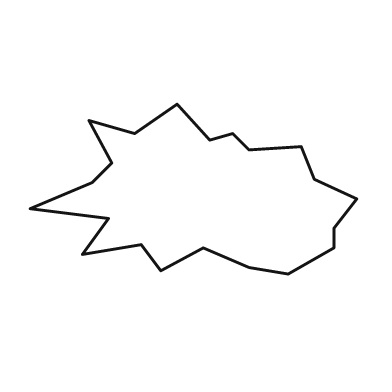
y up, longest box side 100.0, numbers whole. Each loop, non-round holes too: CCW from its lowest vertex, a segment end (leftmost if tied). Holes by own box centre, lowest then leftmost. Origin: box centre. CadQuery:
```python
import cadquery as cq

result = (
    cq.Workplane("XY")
    .moveTo(29.0, -26.0)
    .lineTo(43.0, -18.0)
    .lineTo(43.0, -12.0)
    .lineTo(50.0, -3.0)
    .lineTo(37.0, 3.0)
    .lineTo(33.0, 13.0)
    .lineTo(17.0, 12.0)
    .lineTo(12.0, 17.0)
    .lineTo(5.0, 15.0)
    .lineTo(-5.0, 26.0)
    .lineTo(-18.0, 17.0)
    .lineTo(-32.0, 21.0)
    .lineTo(-25.0, 8.0)
    .lineTo(-31.0, 2.0)
    .lineTo(-50.0, -6.0)
    .lineTo(-26.0, -9.0)
    .lineTo(-34.0, -20.0)
    .lineTo(-16.0, -17.0)
    .lineTo(-10.0, -25.0)
    .lineTo(3.0, -18.0)
    .lineTo(17.0, -24.0)
    .close()
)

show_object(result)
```